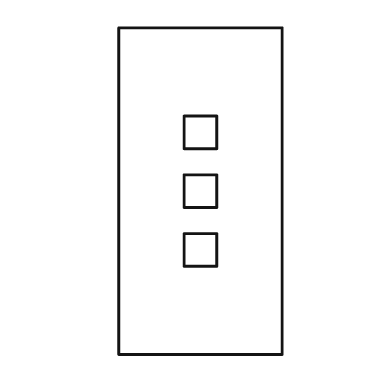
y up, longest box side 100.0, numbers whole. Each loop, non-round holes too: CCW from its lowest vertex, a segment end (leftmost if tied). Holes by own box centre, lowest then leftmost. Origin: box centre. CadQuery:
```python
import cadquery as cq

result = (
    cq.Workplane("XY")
    .moveTo(-25.0, -50.0)
    .lineTo(25.0, -50.0)
    .lineTo(25.0, 50.0)
    .lineTo(-25.0, 50.0)
    .close()
    .moveTo(-5.0, -23.0)
    .lineTo(5.0, -23.0)
    .lineTo(5.0, -13.0)
    .lineTo(-5.0, -13.0)
    .close()
    .moveTo(-5.0, -5.0)
    .lineTo(5.0, -5.0)
    .lineTo(5.0, 5.0)
    .lineTo(-5.0, 5.0)
    .close()
    .moveTo(-5.0, 13.0)
    .lineTo(5.0, 13.0)
    .lineTo(5.0, 23.0)
    .lineTo(-5.0, 23.0)
    .close()
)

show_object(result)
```